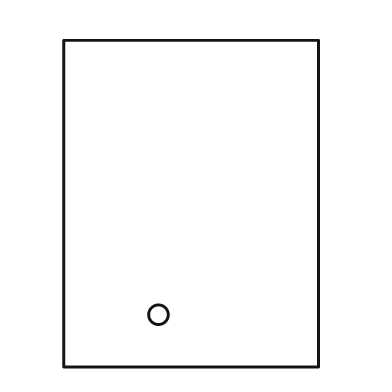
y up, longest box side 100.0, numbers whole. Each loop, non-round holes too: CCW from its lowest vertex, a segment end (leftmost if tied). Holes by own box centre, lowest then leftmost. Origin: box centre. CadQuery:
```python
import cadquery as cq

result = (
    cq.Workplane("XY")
    .moveTo(-39.0, -50.0)
    .lineTo(39.0, -50.0)
    .lineTo(39.0, 50.0)
    .lineTo(-39.0, 50.0)
    .close()
    .moveTo(-10.0, -34.0)
    .circle(3.0)
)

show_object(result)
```